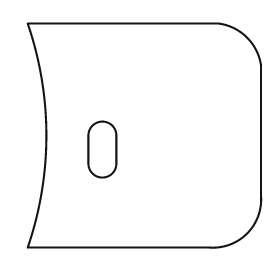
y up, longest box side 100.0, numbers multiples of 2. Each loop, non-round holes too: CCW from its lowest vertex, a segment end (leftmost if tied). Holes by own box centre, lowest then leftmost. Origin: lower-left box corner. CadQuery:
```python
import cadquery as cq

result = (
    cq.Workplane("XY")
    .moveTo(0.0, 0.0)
    .lineTo(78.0, 0.0)
    .threePointArc((94.0, 6.0), (100.0, 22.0))
    .lineTo(100.0, 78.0)
    .threePointArc((94.0, 90.0), (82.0, 96.0))
    .lineTo(0.0, 96.0)
    .threePointArc((8.0, 48.0), (0.0, 0.0))
    .close()
    .moveTo(26.0, 36.0)
    .threePointArc((32.0, 30.0), (38.0, 36.0))
    .lineTo(38.0, 48.0)
    .threePointArc((32.0, 54.0), (26.0, 48.0))
    .close()
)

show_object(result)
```